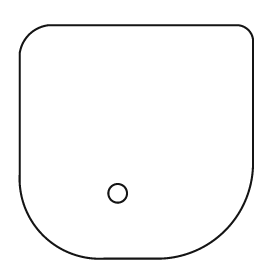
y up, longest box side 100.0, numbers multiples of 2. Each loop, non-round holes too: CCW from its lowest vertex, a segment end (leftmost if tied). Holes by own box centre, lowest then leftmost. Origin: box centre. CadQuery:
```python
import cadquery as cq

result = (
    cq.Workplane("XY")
    .moveTo(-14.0, -50.0)
    .lineTo(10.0, -50.0)
    .threePointArc((38.0, -38.0), (50.0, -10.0))
    .lineTo(50.0, 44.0)
    .threePointArc((48.0, 48.0), (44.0, 50.0))
    .lineTo(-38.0, 50.0)
    .threePointArc((-46.0, 46.0), (-50.0, 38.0))
    .lineTo(-50.0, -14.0)
    .threePointArc((-40.0, -40.0), (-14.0, -50.0))
    .close()
    .moveTo(-8.0, -22.0)
    .circle(4.0)
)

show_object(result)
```